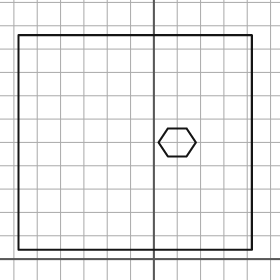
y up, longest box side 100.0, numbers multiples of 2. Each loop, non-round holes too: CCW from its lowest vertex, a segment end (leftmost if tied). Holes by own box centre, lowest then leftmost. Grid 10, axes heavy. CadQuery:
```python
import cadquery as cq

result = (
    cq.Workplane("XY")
    .moveTo(-58.0, 4.0)
    .lineTo(42.0, 4.0)
    .lineTo(42.0, 96.0)
    .lineTo(-58.0, 96.0)
    .close()
    .moveTo(6.0, 44.0)
    .lineTo(14.0, 44.0)
    .lineTo(18.0, 50.0)
    .lineTo(14.0, 56.0)
    .lineTo(6.0, 56.0)
    .lineTo(2.0, 50.0)
    .close()
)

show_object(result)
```